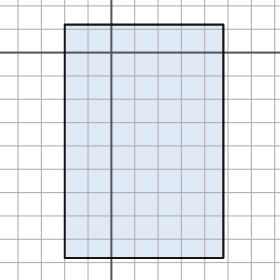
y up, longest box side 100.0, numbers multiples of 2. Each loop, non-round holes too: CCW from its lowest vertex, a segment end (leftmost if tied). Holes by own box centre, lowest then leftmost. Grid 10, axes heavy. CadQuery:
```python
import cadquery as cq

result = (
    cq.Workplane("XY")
    .moveTo(-20.0, -88.0)
    .lineTo(48.0, -88.0)
    .lineTo(48.0, 12.0)
    .lineTo(-20.0, 12.0)
    .close()
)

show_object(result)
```